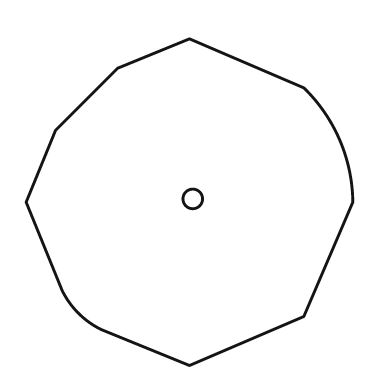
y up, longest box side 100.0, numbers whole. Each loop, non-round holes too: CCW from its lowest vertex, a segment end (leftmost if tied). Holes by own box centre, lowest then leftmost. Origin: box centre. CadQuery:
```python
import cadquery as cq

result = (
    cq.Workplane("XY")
    .moveTo(0.0, -50.0)
    .lineTo(35.0, -35.0)
    .lineTo(50.0, 0.0)
    .threePointArc((46.0, 19.0), (35.0, 35.0))
    .lineTo(0.0, 50.0)
    .lineTo(-22.0, 41.0)
    .lineTo(-41.0, 22.0)
    .lineTo(-50.0, 0.0)
    .lineTo(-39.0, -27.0)
    .threePointArc((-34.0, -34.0), (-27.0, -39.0))
    .close()
    .moveTo(1.0, 1.0)
    .circle(3.0)
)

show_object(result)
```